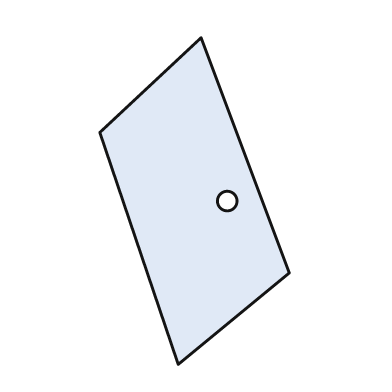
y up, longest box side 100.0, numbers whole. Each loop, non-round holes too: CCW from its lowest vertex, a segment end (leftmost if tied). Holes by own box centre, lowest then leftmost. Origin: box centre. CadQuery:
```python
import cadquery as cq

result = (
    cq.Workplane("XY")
    .moveTo(-5.0, -50.0)
    .lineTo(29.0, -22.0)
    .lineTo(2.0, 50.0)
    .lineTo(-29.0, 21.0)
    .close()
    .moveTo(10.0, 0.0)
    .circle(3.0)
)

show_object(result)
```